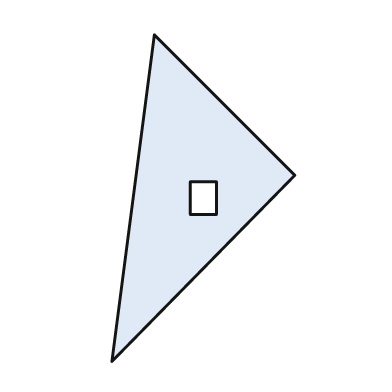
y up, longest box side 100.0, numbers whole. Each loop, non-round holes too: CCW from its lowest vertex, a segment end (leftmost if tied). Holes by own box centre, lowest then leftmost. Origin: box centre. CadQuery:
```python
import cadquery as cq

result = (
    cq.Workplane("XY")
    .moveTo(-28.0, -50.0)
    .lineTo(28.0, 7.0)
    .lineTo(-15.0, 50.0)
    .close()
    .moveTo(-4.0, -5.0)
    .lineTo(4.0, -5.0)
    .lineTo(4.0, 5.0)
    .lineTo(-4.0, 5.0)
    .close()
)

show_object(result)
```